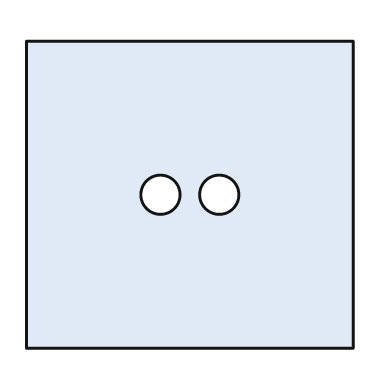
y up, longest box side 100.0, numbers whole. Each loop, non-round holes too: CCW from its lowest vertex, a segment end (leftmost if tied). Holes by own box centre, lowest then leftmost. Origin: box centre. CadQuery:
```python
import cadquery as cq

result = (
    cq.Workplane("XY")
    .moveTo(-50.0, -47.0)
    .lineTo(50.0, -47.0)
    .lineTo(50.0, 47.0)
    .lineTo(-50.0, 47.0)
    .close()
    .moveTo(-9.0, 0.0)
    .circle(6.0)
    .moveTo(9.0, 0.0)
    .circle(6.0)
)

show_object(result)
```